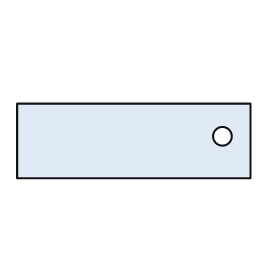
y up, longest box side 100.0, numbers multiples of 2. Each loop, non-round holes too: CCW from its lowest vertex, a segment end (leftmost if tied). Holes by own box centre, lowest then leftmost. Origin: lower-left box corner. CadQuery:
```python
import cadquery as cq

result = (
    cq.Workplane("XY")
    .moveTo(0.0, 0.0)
    .lineTo(100.0, 0.0)
    .lineTo(100.0, 32.0)
    .lineTo(0.0, 32.0)
    .close()
    .moveTo(88.0, 18.0)
    .circle(4.0)
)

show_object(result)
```